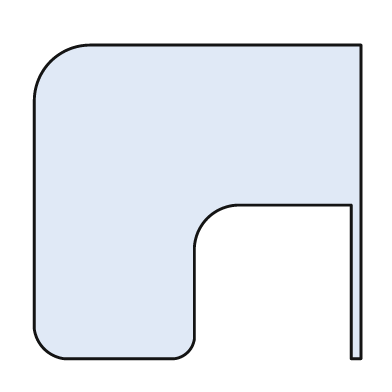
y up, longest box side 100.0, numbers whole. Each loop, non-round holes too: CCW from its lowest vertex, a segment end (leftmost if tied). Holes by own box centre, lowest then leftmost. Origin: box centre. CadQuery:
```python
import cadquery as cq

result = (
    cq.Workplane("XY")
    .moveTo(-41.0, -48.0)
    .lineTo(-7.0, -48.0)
    .threePointArc((-3.0, -46.0), (-1.0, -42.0))
    .lineTo(-1.0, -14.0)
    .threePointArc((3.0, -5.0), (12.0, -1.0))
    .lineTo(47.0, -1.0)
    .lineTo(47.0, -48.0)
    .lineTo(50.0, -48.0)
    .lineTo(50.0, 48.0)
    .lineTo(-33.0, 48.0)
    .threePointArc((-45.0, 43.0), (-50.0, 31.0))
    .lineTo(-50.0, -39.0)
    .threePointArc((-47.0, -45.0), (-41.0, -48.0))
    .close()
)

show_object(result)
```